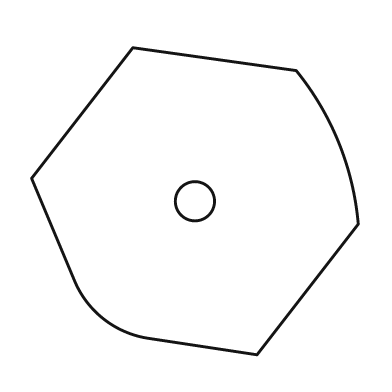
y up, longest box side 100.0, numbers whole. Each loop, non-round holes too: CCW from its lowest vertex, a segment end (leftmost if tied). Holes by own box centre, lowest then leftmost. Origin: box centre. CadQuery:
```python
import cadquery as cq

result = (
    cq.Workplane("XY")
    .moveTo(19.0, -47.0)
    .lineTo(50.0, -7.0)
    .threePointArc((44.0, 18.0), (31.0, 40.0))
    .lineTo(-19.0, 47.0)
    .lineTo(-50.0, 7.0)
    .lineTo(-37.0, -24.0)
    .threePointArc((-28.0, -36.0), (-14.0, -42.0))
    .close()
    .moveTo(0.0, 0.0)
    .circle(6.0)
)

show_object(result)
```